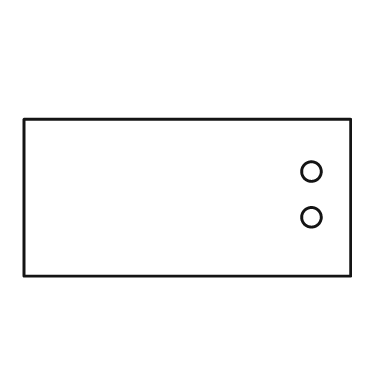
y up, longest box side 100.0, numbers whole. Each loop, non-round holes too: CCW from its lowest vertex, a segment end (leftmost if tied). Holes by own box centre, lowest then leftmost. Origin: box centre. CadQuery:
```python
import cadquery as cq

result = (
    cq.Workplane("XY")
    .moveTo(-50.0, -24.0)
    .lineTo(50.0, -24.0)
    .lineTo(50.0, 24.0)
    .lineTo(-50.0, 24.0)
    .close()
    .moveTo(38.0, -6.0)
    .circle(3.0)
    .moveTo(38.0, 8.0)
    .circle(3.0)
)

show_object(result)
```